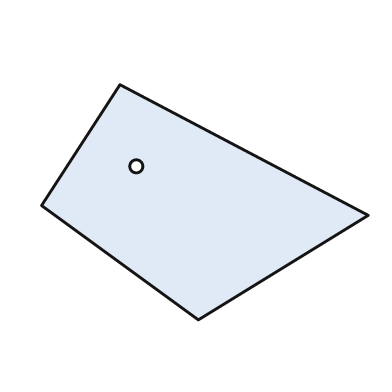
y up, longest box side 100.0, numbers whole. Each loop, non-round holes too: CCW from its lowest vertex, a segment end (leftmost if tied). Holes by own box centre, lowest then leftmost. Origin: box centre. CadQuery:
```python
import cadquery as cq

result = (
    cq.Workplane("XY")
    .moveTo(-2.0, -36.0)
    .lineTo(50.0, -4.0)
    .lineTo(-26.0, 36.0)
    .lineTo(-50.0, -1.0)
    .close()
    .moveTo(-21.0, 11.0)
    .circle(2.0)
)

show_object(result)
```